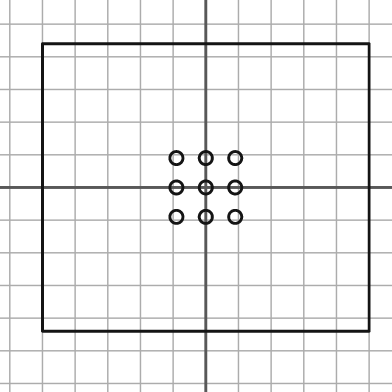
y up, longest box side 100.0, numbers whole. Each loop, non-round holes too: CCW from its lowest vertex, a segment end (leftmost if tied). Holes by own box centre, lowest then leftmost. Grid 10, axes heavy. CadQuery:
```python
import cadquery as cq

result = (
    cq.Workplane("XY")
    .moveTo(-50.0, -44.0)
    .lineTo(50.0, -44.0)
    .lineTo(50.0, 44.0)
    .lineTo(-50.0, 44.0)
    .close()
    .moveTo(-9.0, -9.0)
    .circle(2.0)
    .moveTo(0.0, -9.0)
    .circle(2.0)
    .moveTo(9.0, -9.0)
    .circle(2.0)
    .moveTo(-9.0, 0.0)
    .circle(2.0)
    .moveTo(0.0, 0.0)
    .circle(2.0)
    .moveTo(9.0, 0.0)
    .circle(2.0)
    .moveTo(-9.0, 9.0)
    .circle(2.0)
    .moveTo(0.0, 9.0)
    .circle(2.0)
    .moveTo(9.0, 9.0)
    .circle(2.0)
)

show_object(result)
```